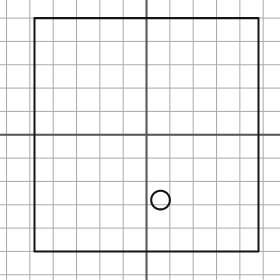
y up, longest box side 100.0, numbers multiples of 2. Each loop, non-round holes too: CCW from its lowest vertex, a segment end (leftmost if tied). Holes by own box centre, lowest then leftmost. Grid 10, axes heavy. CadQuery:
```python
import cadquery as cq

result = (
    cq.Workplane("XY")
    .moveTo(-48.0, -50.0)
    .lineTo(48.0, -50.0)
    .lineTo(48.0, 50.0)
    .lineTo(-48.0, 50.0)
    .close()
    .moveTo(6.0, -28.0)
    .circle(4.0)
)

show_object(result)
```